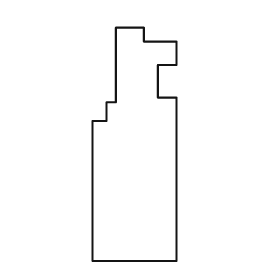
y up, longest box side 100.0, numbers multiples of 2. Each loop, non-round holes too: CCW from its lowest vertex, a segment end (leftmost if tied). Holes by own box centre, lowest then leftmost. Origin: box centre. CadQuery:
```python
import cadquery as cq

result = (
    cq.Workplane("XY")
    .moveTo(-18.0, -50.0)
    .lineTo(18.0, -50.0)
    .lineTo(18.0, 20.0)
    .lineTo(10.0, 20.0)
    .lineTo(10.0, 34.0)
    .lineTo(18.0, 34.0)
    .lineTo(18.0, 44.0)
    .lineTo(4.0, 44.0)
    .lineTo(4.0, 50.0)
    .lineTo(-8.0, 50.0)
    .lineTo(-8.0, 18.0)
    .lineTo(-12.0, 18.0)
    .lineTo(-12.0, 10.0)
    .lineTo(-18.0, 10.0)
    .close()
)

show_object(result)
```